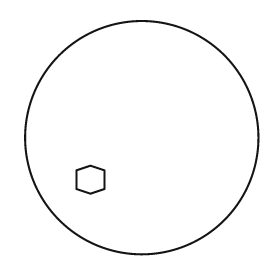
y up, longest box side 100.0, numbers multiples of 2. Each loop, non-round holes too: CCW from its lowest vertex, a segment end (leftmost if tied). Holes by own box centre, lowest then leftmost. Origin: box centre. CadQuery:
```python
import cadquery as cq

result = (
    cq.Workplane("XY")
    .moveTo(0.0, 0.0)
    .circle(50.0)
    .moveTo(-22.0, -24.0)
    .lineTo(-16.0, -22.0)
    .lineTo(-16.0, -14.0)
    .lineTo(-22.0, -12.0)
    .lineTo(-28.0, -14.0)
    .lineTo(-28.0, -22.0)
    .close()
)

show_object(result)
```